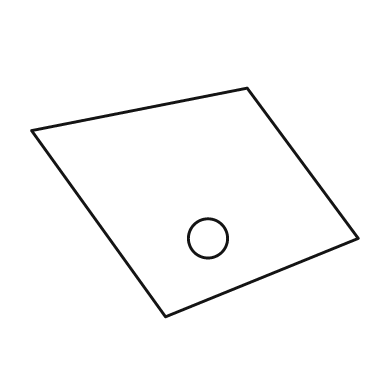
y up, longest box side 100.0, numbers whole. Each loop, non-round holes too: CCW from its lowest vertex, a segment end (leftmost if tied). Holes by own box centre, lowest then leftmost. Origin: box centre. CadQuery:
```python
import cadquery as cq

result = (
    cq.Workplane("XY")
    .moveTo(-9.0, -35.0)
    .lineTo(50.0, -11.0)
    .lineTo(16.0, 35.0)
    .lineTo(-50.0, 22.0)
    .close()
    .moveTo(4.0, -11.0)
    .circle(6.0)
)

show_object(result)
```